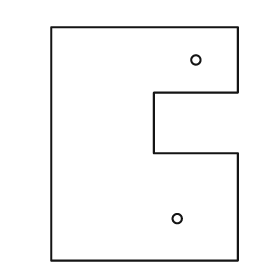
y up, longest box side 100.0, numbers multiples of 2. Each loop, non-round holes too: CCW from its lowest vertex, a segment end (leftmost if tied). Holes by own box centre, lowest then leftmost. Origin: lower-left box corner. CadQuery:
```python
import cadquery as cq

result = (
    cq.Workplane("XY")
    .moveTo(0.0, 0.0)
    .lineTo(80.0, 0.0)
    .lineTo(80.0, 46.0)
    .lineTo(44.0, 46.0)
    .lineTo(44.0, 72.0)
    .lineTo(80.0, 72.0)
    .lineTo(80.0, 100.0)
    .lineTo(0.0, 100.0)
    .close()
    .moveTo(54.0, 18.0)
    .circle(2.0)
    .moveTo(62.0, 86.0)
    .circle(2.0)
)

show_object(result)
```